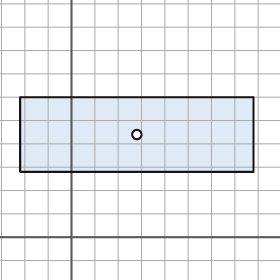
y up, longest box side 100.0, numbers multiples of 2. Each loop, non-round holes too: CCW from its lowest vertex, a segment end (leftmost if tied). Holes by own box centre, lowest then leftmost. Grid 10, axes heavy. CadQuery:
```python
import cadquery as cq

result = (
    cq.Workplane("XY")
    .moveTo(-22.0, 28.0)
    .lineTo(78.0, 28.0)
    .lineTo(78.0, 60.0)
    .lineTo(-22.0, 60.0)
    .close()
    .moveTo(28.0, 44.0)
    .circle(2.0)
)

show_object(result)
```